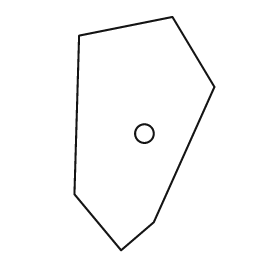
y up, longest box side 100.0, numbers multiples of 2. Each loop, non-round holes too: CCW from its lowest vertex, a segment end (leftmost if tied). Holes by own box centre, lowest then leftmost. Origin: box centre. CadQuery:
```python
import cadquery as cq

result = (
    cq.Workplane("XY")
    .moveTo(-10.0, -50.0)
    .lineTo(4.0, -38.0)
    .lineTo(30.0, 20.0)
    .lineTo(12.0, 50.0)
    .lineTo(-28.0, 42.0)
    .lineTo(-30.0, -26.0)
    .close()
    .moveTo(0.0, 0.0)
    .circle(4.0)
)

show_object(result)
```